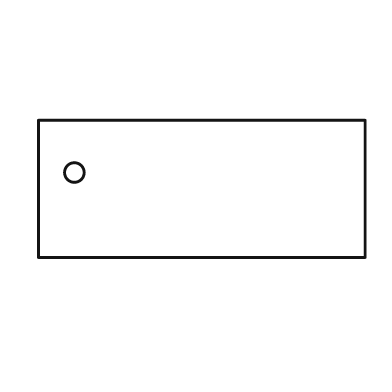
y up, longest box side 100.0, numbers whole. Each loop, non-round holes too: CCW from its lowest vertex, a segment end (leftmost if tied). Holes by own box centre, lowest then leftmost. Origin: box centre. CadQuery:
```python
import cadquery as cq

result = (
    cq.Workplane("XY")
    .moveTo(-50.0, -21.0)
    .lineTo(50.0, -21.0)
    .lineTo(50.0, 21.0)
    .lineTo(-50.0, 21.0)
    .close()
    .moveTo(-39.0, 5.0)
    .circle(3.0)
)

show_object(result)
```